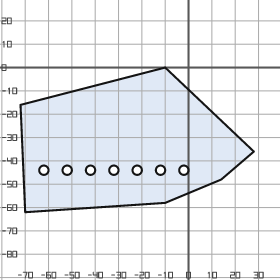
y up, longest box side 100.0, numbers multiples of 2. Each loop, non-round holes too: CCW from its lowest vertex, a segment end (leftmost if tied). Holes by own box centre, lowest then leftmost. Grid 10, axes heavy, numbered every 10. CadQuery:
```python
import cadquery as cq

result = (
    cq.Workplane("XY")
    .moveTo(-70.0, -62.0)
    .lineTo(-10.0, -58.0)
    .lineTo(14.0, -48.0)
    .lineTo(28.0, -36.0)
    .lineTo(-10.0, 0.0)
    .lineTo(-72.0, -16.0)
    .close()
    .moveTo(-62.0, -44.0)
    .circle(2.0)
    .moveTo(-52.0, -44.0)
    .circle(2.0)
    .moveTo(-42.0, -44.0)
    .circle(2.0)
    .moveTo(-32.0, -44.0)
    .circle(2.0)
    .moveTo(-22.0, -44.0)
    .circle(2.0)
    .moveTo(-12.0, -44.0)
    .circle(2.0)
    .moveTo(-2.0, -44.0)
    .circle(2.0)
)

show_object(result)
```